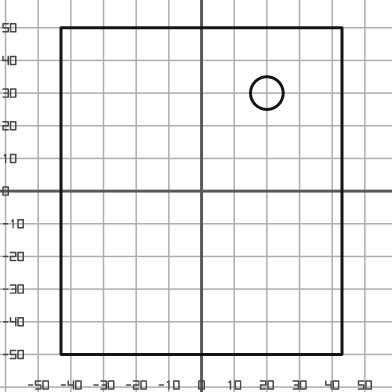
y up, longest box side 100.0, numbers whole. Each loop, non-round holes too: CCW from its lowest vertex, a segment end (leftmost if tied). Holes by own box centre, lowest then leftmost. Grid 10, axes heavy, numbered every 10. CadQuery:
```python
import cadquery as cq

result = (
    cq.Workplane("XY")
    .moveTo(-43.0, -50.0)
    .lineTo(43.0, -50.0)
    .lineTo(43.0, 50.0)
    .lineTo(-43.0, 50.0)
    .close()
    .moveTo(20.0, 30.0)
    .circle(5.0)
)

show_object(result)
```